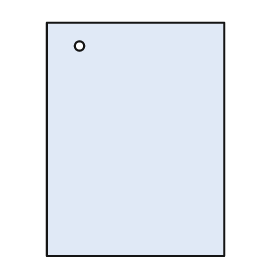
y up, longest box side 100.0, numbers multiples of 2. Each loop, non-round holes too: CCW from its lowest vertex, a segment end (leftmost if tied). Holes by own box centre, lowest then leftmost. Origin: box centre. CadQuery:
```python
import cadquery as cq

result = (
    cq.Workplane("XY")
    .moveTo(-38.0, -50.0)
    .lineTo(38.0, -50.0)
    .lineTo(38.0, 50.0)
    .lineTo(-38.0, 50.0)
    .close()
    .moveTo(-24.0, 40.0)
    .circle(2.0)
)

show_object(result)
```